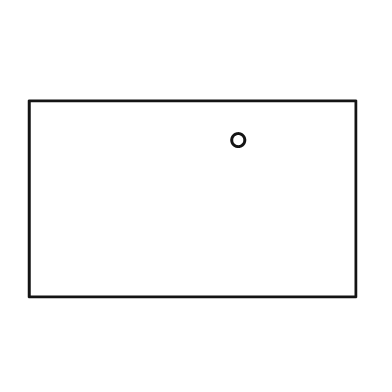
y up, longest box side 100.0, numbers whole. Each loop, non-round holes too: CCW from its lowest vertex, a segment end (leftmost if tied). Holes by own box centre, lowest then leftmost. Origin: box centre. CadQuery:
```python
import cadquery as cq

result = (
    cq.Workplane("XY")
    .moveTo(-50.0, -30.0)
    .lineTo(50.0, -30.0)
    .lineTo(50.0, 30.0)
    .lineTo(-50.0, 30.0)
    .close()
    .moveTo(14.0, 18.0)
    .circle(2.0)
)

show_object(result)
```